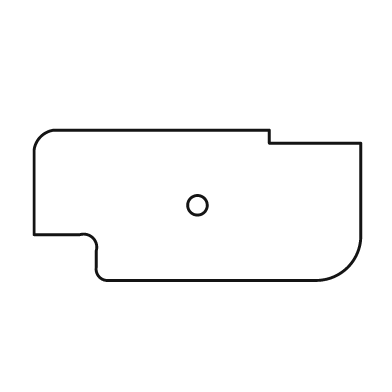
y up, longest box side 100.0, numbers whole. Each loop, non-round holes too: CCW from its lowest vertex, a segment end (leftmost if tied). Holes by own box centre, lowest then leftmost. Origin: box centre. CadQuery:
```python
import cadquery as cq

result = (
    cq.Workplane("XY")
    .moveTo(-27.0, -23.0)
    .lineTo(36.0, -23.0)
    .threePointArc((46.0, -19.0), (50.0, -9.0))
    .lineTo(50.0, 19.0)
    .lineTo(22.0, 19.0)
    .lineTo(22.0, 23.0)
    .lineTo(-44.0, 23.0)
    .threePointArc((-48.0, 21.0), (-50.0, 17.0))
    .lineTo(-50.0, -9.0)
    .lineTo(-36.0, -9.0)
    .threePointArc((-32.0, -10.0), (-31.0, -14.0))
    .lineTo(-31.0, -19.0)
    .threePointArc((-30.0, -22.0), (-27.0, -23.0))
    .close()
    .moveTo(0.0, 0.0)
    .circle(3.0)
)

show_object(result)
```